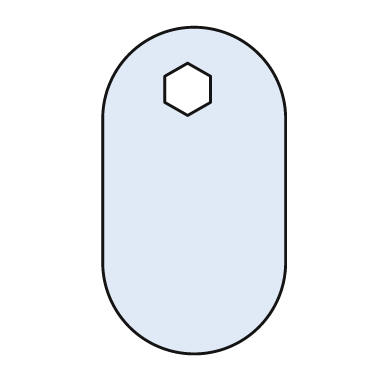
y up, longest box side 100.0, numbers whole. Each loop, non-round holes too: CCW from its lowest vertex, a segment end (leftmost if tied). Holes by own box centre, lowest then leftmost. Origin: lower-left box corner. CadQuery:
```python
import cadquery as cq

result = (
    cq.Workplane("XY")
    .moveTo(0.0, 28.0)
    .threePointArc((28.0, 0.0), (56.0, 28.0))
    .lineTo(56.0, 72.0)
    .threePointArc((28.0, 100.0), (0.0, 72.0))
    .close()
    .moveTo(26.0, 73.0)
    .lineTo(33.0, 77.0)
    .lineTo(33.0, 85.0)
    .lineTo(26.0, 89.0)
    .lineTo(19.0, 85.0)
    .lineTo(19.0, 77.0)
    .close()
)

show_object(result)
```